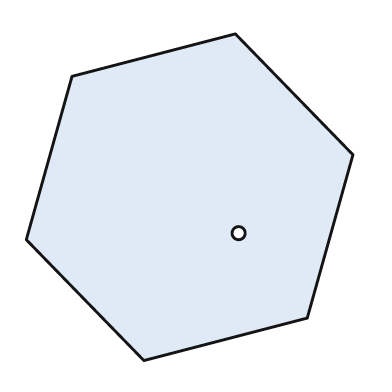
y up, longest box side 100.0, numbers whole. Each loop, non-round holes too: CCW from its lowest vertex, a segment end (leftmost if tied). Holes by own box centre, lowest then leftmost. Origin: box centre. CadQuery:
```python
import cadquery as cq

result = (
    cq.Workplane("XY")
    .moveTo(-14.0, -50.0)
    .lineTo(36.0, -37.0)
    .lineTo(50.0, 13.0)
    .lineTo(14.0, 50.0)
    .lineTo(-36.0, 37.0)
    .lineTo(-50.0, -13.0)
    .close()
    .moveTo(15.0, -11.0)
    .circle(2.0)
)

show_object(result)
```